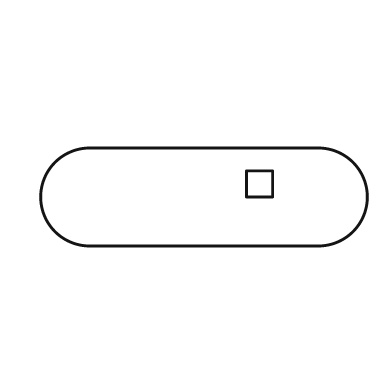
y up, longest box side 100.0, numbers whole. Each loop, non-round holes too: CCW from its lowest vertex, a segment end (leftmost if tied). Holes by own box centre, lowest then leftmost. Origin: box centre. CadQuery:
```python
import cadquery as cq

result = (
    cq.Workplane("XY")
    .moveTo(-35.0, -15.0)
    .lineTo(35.0, -15.0)
    .threePointArc((50.0, 0.0), (35.0, 15.0))
    .lineTo(-35.0, 15.0)
    .threePointArc((-50.0, 0.0), (-35.0, -15.0))
    .close()
    .moveTo(13.0, 0.0)
    .lineTo(21.0, 0.0)
    .lineTo(21.0, 8.0)
    .lineTo(13.0, 8.0)
    .close()
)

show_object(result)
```